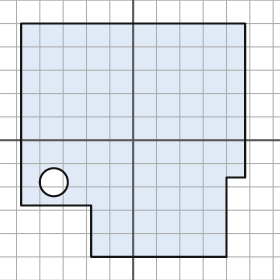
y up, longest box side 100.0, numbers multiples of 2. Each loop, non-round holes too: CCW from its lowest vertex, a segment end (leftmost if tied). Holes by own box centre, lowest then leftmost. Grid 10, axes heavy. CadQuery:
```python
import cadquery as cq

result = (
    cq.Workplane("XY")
    .moveTo(-18.0, -50.0)
    .lineTo(40.0, -50.0)
    .lineTo(40.0, -16.0)
    .lineTo(48.0, -16.0)
    .lineTo(48.0, 50.0)
    .lineTo(-48.0, 50.0)
    .lineTo(-48.0, -28.0)
    .lineTo(-18.0, -28.0)
    .close()
    .moveTo(-34.0, -18.0)
    .circle(6.0)
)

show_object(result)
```